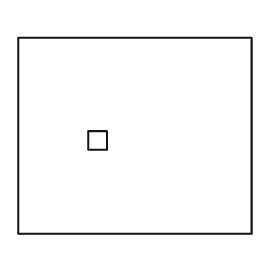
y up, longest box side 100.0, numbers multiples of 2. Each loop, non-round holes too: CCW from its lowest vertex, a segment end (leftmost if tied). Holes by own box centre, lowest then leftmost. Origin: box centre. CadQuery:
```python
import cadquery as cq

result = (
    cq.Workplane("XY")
    .moveTo(-50.0, -42.0)
    .lineTo(50.0, -42.0)
    .lineTo(50.0, 42.0)
    .lineTo(-50.0, 42.0)
    .close()
    .moveTo(-20.0, -6.0)
    .lineTo(-12.0, -6.0)
    .lineTo(-12.0, 2.0)
    .lineTo(-20.0, 2.0)
    .close()
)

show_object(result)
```